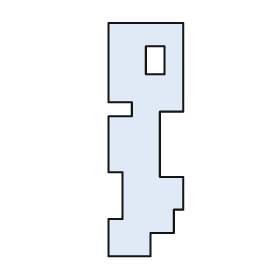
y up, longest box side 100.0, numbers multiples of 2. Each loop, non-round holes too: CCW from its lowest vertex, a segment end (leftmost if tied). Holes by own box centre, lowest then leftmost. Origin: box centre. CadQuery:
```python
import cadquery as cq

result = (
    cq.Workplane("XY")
    .moveTo(-16.0, -50.0)
    .lineTo(2.0, -50.0)
    .lineTo(2.0, -40.0)
    .lineTo(12.0, -40.0)
    .lineTo(12.0, -30.0)
    .lineTo(16.0, -30.0)
    .lineTo(16.0, -16.0)
    .lineTo(6.0, -16.0)
    .lineTo(6.0, 12.0)
    .lineTo(16.0, 12.0)
    .lineTo(16.0, 50.0)
    .lineTo(-16.0, 50.0)
    .lineTo(-16.0, 16.0)
    .lineTo(-6.0, 16.0)
    .lineTo(-6.0, 10.0)
    .lineTo(-16.0, 10.0)
    .lineTo(-16.0, -14.0)
    .lineTo(-10.0, -14.0)
    .lineTo(-10.0, -34.0)
    .lineTo(-16.0, -34.0)
    .close()
    .moveTo(0.0, 28.0)
    .lineTo(8.0, 28.0)
    .lineTo(8.0, 40.0)
    .lineTo(0.0, 40.0)
    .close()
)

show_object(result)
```